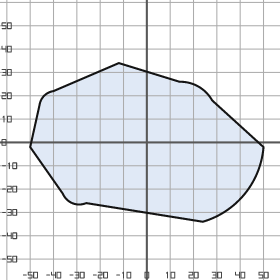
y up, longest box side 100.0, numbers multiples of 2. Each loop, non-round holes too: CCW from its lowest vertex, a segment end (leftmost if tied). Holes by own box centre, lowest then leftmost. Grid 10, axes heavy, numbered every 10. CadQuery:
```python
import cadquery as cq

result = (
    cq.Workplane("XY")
    .moveTo(24.0, -34.0)
    .threePointArc((42.0, -22.0), (50.0, -2.0))
    .lineTo(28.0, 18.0)
    .threePointArc((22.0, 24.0), (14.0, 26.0))
    .lineTo(-12.0, 34.0)
    .lineTo(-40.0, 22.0)
    .threePointArc((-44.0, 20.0), (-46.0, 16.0))
    .lineTo(-50.0, -2.0)
    .lineTo(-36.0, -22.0)
    .threePointArc((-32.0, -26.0), (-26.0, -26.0))
    .close()
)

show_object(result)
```